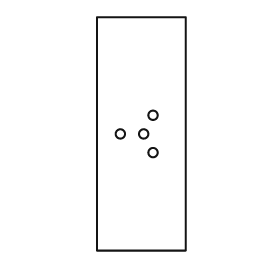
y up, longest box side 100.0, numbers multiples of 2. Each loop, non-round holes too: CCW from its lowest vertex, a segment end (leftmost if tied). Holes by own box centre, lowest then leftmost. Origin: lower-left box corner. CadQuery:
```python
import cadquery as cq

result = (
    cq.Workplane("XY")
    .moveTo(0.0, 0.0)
    .lineTo(38.0, 0.0)
    .lineTo(38.0, 100.0)
    .lineTo(0.0, 100.0)
    .close()
    .moveTo(24.0, 42.0)
    .circle(2.0)
    .moveTo(10.0, 50.0)
    .circle(2.0)
    .moveTo(20.0, 50.0)
    .circle(2.0)
    .moveTo(24.0, 58.0)
    .circle(2.0)
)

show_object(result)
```